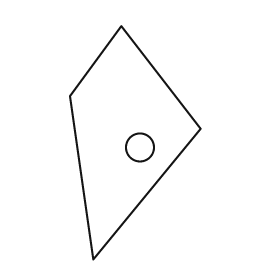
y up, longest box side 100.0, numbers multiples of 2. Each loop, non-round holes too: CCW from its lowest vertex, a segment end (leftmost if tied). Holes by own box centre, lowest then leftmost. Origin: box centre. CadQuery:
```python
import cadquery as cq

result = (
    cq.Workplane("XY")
    .moveTo(-18.0, -50.0)
    .lineTo(28.0, 6.0)
    .lineTo(-6.0, 50.0)
    .lineTo(-28.0, 20.0)
    .close()
    .moveTo(2.0, -2.0)
    .circle(6.0)
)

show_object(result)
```